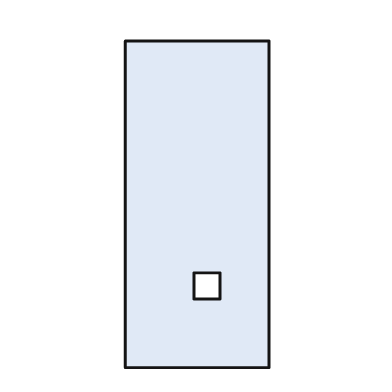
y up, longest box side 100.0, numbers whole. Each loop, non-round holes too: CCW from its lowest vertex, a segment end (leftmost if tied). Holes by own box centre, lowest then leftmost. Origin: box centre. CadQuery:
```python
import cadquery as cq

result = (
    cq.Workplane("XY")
    .moveTo(-22.0, -50.0)
    .lineTo(22.0, -50.0)
    .lineTo(22.0, 50.0)
    .lineTo(-22.0, 50.0)
    .close()
    .moveTo(-1.0, -29.0)
    .lineTo(7.0, -29.0)
    .lineTo(7.0, -21.0)
    .lineTo(-1.0, -21.0)
    .close()
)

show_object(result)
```